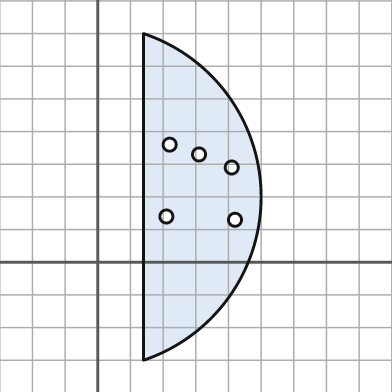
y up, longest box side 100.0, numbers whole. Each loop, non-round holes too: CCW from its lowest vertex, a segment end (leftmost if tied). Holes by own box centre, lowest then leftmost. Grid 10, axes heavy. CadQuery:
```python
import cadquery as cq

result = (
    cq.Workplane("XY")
    .moveTo(14.0, -30.0)
    .threePointArc((50.0, 20.0), (14.0, 70.0))
    .close()
    .moveTo(42.0, 13.0)
    .circle(2.0)
    .moveTo(21.0, 14.0)
    .circle(2.0)
    .moveTo(41.0, 29.0)
    .circle(2.0)
    .moveTo(31.0, 33.0)
    .circle(2.0)
    .moveTo(22.0, 36.0)
    .circle(2.0)
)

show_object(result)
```